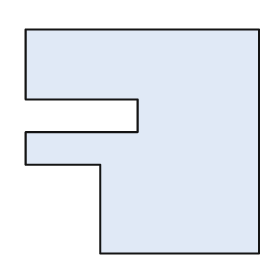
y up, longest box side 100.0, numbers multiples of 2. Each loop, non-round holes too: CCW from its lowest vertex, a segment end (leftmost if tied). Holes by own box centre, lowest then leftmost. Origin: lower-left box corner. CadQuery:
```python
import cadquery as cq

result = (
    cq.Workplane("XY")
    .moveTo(32.0, 0.0)
    .lineTo(100.0, 0.0)
    .lineTo(100.0, 96.0)
    .lineTo(0.0, 96.0)
    .lineTo(0.0, 66.0)
    .lineTo(48.0, 66.0)
    .lineTo(48.0, 52.0)
    .lineTo(0.0, 52.0)
    .lineTo(0.0, 38.0)
    .lineTo(32.0, 38.0)
    .close()
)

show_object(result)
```